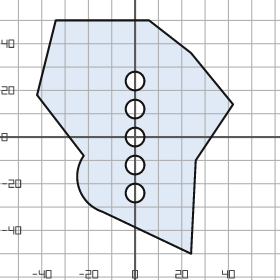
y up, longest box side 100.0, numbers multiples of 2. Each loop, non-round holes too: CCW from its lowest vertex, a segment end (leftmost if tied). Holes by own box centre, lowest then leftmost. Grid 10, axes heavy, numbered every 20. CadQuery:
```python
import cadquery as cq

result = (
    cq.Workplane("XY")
    .moveTo(24.0, -50.0)
    .lineTo(26.0, -10.0)
    .lineTo(42.0, 14.0)
    .lineTo(24.0, 36.0)
    .lineTo(6.0, 50.0)
    .lineTo(-34.0, 50.0)
    .lineTo(-42.0, 18.0)
    .lineTo(-22.0, -8.0)
    .threePointArc((-24.0, -22.0), (-14.0, -32.0))
    .close()
    .moveTo(0.0, -24.0)
    .circle(4.0)
    .moveTo(0.0, -12.0)
    .circle(4.0)
    .moveTo(0.0, 0.0)
    .circle(4.0)
    .moveTo(0.0, 12.0)
    .circle(4.0)
    .moveTo(0.0, 24.0)
    .circle(4.0)
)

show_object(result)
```